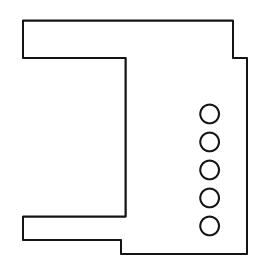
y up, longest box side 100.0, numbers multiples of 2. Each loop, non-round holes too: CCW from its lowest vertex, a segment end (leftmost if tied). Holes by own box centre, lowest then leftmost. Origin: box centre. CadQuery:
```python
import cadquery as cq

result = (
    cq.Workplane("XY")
    .moveTo(-6.0, -50.0)
    .lineTo(48.0, -50.0)
    .lineTo(48.0, 34.0)
    .lineTo(42.0, 34.0)
    .lineTo(42.0, 50.0)
    .lineTo(-48.0, 50.0)
    .lineTo(-48.0, 34.0)
    .lineTo(-4.0, 34.0)
    .lineTo(-4.0, -34.0)
    .lineTo(-48.0, -34.0)
    .lineTo(-48.0, -44.0)
    .lineTo(-6.0, -44.0)
    .close()
    .moveTo(32.0, -38.0)
    .circle(4.0)
    .moveTo(32.0, -26.0)
    .circle(4.0)
    .moveTo(32.0, -14.0)
    .circle(4.0)
    .moveTo(32.0, -2.0)
    .circle(4.0)
    .moveTo(32.0, 10.0)
    .circle(4.0)
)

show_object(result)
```